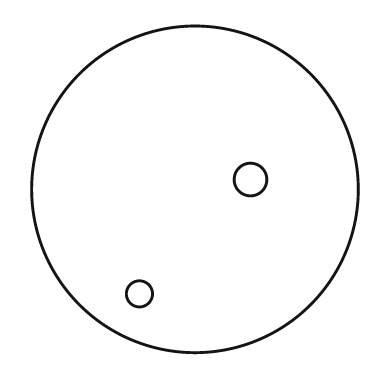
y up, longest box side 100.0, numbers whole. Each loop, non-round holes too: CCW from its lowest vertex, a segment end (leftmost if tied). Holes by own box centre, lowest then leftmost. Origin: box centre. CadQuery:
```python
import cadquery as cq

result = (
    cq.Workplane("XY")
    .moveTo(0.0, 0.0)
    .circle(50.0)
    .moveTo(-17.0, -32.0)
    .circle(4.0)
    .moveTo(17.0, 3.0)
    .circle(5.0)
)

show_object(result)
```